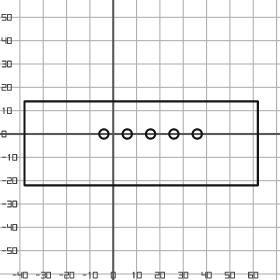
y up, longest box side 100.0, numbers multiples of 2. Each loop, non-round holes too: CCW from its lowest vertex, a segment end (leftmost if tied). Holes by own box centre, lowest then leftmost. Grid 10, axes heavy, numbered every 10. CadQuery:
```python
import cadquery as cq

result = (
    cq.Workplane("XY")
    .moveTo(-38.0, -22.0)
    .lineTo(62.0, -22.0)
    .lineTo(62.0, 14.0)
    .lineTo(-38.0, 14.0)
    .close()
    .moveTo(-4.0, 0.0)
    .circle(2.0)
    .moveTo(6.0, 0.0)
    .circle(2.0)
    .moveTo(16.0, 0.0)
    .circle(2.0)
    .moveTo(26.0, 0.0)
    .circle(2.0)
    .moveTo(36.0, 0.0)
    .circle(2.0)
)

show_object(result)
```